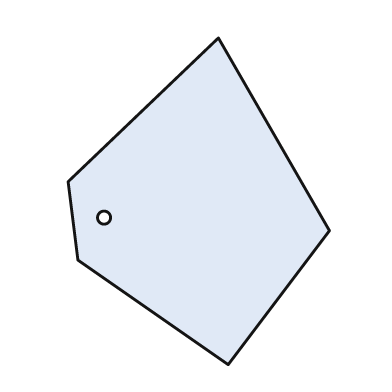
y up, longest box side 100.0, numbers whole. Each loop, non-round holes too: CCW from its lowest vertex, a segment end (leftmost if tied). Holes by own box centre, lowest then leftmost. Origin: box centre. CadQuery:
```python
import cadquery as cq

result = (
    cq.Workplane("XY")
    .moveTo(9.0, -50.0)
    .lineTo(40.0, -9.0)
    .lineTo(6.0, 50.0)
    .lineTo(-40.0, 6.0)
    .lineTo(-37.0, -18.0)
    .close()
    .moveTo(-29.0, -5.0)
    .circle(2.0)
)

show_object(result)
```